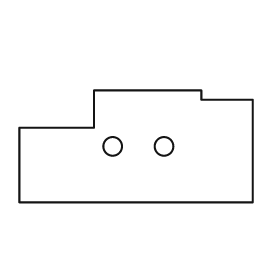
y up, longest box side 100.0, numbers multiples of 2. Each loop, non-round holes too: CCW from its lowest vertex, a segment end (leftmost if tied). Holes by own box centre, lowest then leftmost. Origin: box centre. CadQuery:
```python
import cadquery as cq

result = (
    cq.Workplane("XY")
    .moveTo(-50.0, -24.0)
    .lineTo(50.0, -24.0)
    .lineTo(50.0, 20.0)
    .lineTo(28.0, 20.0)
    .lineTo(28.0, 24.0)
    .lineTo(-18.0, 24.0)
    .lineTo(-18.0, 8.0)
    .lineTo(-50.0, 8.0)
    .close()
    .moveTo(-10.0, 0.0)
    .circle(4.0)
    .moveTo(12.0, 0.0)
    .circle(4.0)
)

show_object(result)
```